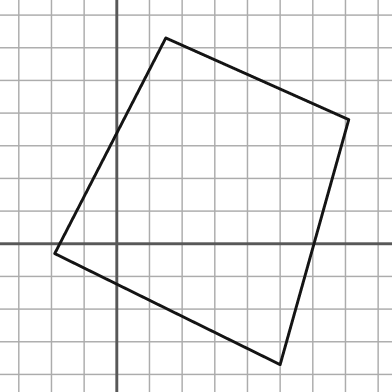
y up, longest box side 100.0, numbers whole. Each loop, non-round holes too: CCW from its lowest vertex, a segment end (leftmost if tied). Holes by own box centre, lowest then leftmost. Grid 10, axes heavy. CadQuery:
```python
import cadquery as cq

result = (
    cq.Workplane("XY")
    .moveTo(50.0, -37.0)
    .lineTo(71.0, 38.0)
    .lineTo(15.0, 63.0)
    .lineTo(-19.0, -3.0)
    .close()
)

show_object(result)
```